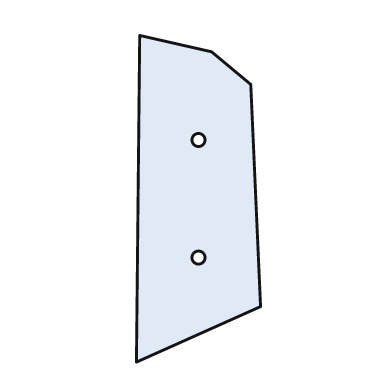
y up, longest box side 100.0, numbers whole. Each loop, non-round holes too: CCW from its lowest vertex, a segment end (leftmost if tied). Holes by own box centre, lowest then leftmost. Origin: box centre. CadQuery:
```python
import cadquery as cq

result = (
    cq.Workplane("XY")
    .moveTo(-19.0, -50.0)
    .lineTo(19.0, -33.0)
    .lineTo(16.0, 35.0)
    .lineTo(4.0, 45.0)
    .lineTo(-18.0, 50.0)
    .close()
    .moveTo(0.0, -18.0)
    .circle(2.0)
    .moveTo(0.0, 18.0)
    .circle(2.0)
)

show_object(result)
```